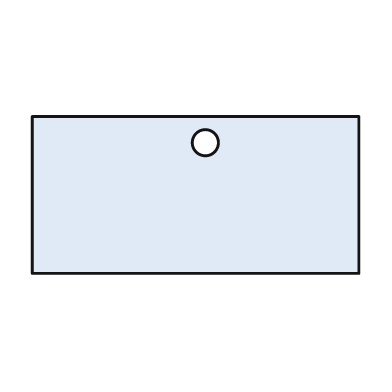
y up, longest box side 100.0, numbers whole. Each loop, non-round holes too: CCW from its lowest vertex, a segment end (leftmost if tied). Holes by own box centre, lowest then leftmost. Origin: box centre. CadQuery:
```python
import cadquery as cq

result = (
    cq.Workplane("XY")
    .moveTo(-50.0, -24.0)
    .lineTo(50.0, -24.0)
    .lineTo(50.0, 24.0)
    .lineTo(-50.0, 24.0)
    .close()
    .moveTo(3.0, 16.0)
    .circle(4.0)
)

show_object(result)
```